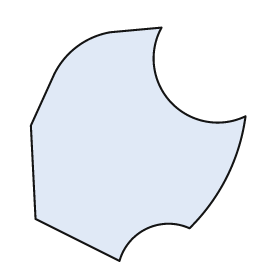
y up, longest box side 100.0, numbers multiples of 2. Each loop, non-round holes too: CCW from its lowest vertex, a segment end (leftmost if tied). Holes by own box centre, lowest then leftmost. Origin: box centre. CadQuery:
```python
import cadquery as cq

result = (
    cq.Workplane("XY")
    .moveTo(-8.0, -50.0)
    .threePointArc((4.0, -36.0), (22.0, -36.0))
    .threePointArc((38.0, -14.0), (46.0, 12.0))
    .threePointArc((14.0, 18.0), (10.0, 50.0))
    .lineTo(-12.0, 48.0)
    .threePointArc((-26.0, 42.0), (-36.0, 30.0))
    .lineTo(-46.0, 8.0)
    .lineTo(-44.0, -32.0)
    .close()
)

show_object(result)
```